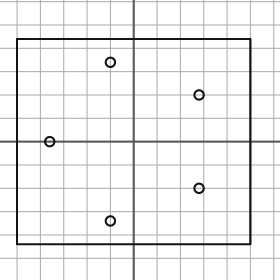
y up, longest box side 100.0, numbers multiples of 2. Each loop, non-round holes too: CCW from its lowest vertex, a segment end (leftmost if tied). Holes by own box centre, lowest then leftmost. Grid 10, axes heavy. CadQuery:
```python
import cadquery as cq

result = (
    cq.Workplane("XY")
    .moveTo(-50.0, -44.0)
    .lineTo(50.0, -44.0)
    .lineTo(50.0, 44.0)
    .lineTo(-50.0, 44.0)
    .close()
    .moveTo(-10.0, -34.0)
    .circle(2.0)
    .moveTo(28.0, -20.0)
    .circle(2.0)
    .moveTo(-36.0, 0.0)
    .circle(2.0)
    .moveTo(28.0, 20.0)
    .circle(2.0)
    .moveTo(-10.0, 34.0)
    .circle(2.0)
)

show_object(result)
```